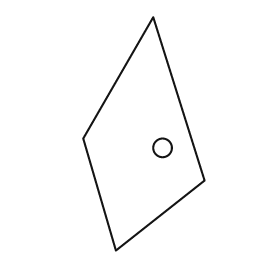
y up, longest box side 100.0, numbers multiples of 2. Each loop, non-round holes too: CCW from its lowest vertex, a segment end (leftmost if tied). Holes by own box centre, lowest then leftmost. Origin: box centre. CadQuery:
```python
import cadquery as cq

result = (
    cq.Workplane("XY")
    .moveTo(-12.0, -50.0)
    .lineTo(26.0, -20.0)
    .lineTo(4.0, 50.0)
    .lineTo(-26.0, -2.0)
    .close()
    .moveTo(8.0, -6.0)
    .circle(4.0)
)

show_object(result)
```